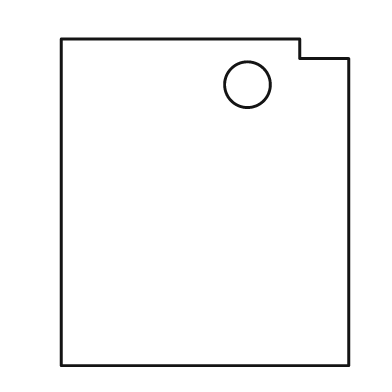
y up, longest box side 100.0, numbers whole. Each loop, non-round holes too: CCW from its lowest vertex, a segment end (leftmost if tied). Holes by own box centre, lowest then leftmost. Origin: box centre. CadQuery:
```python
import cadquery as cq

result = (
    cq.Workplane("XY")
    .moveTo(-44.0, -50.0)
    .lineTo(44.0, -50.0)
    .lineTo(44.0, 44.0)
    .lineTo(29.0, 44.0)
    .lineTo(29.0, 50.0)
    .lineTo(-44.0, 50.0)
    .close()
    .moveTo(13.0, 36.0)
    .circle(7.0)
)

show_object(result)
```